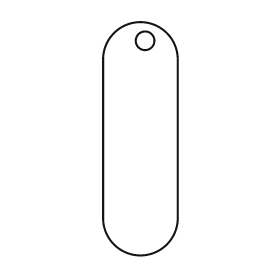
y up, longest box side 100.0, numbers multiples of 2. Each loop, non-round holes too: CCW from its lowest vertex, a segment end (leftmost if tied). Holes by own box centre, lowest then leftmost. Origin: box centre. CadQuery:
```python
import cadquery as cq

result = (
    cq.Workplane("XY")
    .moveTo(-16.0, -34.0)
    .threePointArc((0.0, -50.0), (16.0, -34.0))
    .lineTo(16.0, 34.0)
    .threePointArc((0.0, 50.0), (-16.0, 34.0))
    .close()
    .moveTo(2.0, 42.0)
    .circle(4.0)
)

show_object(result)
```